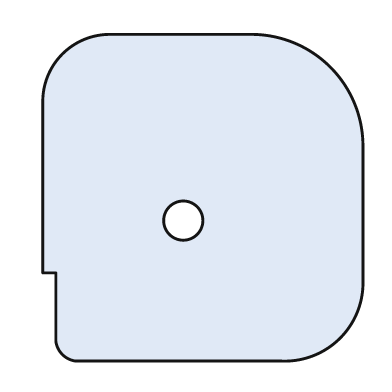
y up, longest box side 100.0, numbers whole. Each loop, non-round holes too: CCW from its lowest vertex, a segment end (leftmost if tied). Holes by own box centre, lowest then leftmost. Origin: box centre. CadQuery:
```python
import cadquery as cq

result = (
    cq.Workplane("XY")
    .moveTo(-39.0, -50.0)
    .lineTo(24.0, -50.0)
    .threePointArc((42.0, -43.0), (49.0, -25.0))
    .lineTo(49.0, 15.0)
    .threePointArc((39.0, 40.0), (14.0, 50.0))
    .lineTo(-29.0, 50.0)
    .threePointArc((-43.0, 44.0), (-49.0, 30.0))
    .lineTo(-49.0, -23.0)
    .lineTo(-45.0, -23.0)
    .lineTo(-45.0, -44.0)
    .threePointArc((-43.0, -48.0), (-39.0, -50.0))
    .close()
    .moveTo(-6.0, -7.0)
    .circle(6.0)
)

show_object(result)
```